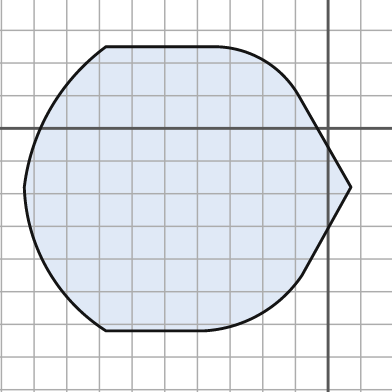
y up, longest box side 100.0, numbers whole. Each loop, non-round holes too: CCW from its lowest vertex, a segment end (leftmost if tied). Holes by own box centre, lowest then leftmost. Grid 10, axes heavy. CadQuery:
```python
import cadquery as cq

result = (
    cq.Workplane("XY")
    .moveTo(-68.0, -62.0)
    .lineTo(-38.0, -62.0)
    .threePointArc((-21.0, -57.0), (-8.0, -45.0))
    .lineTo(7.0, -18.0)
    .lineTo(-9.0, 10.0)
    .threePointArc((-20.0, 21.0), (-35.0, 25.0))
    .lineTo(-68.0, 25.0)
    .threePointArc((-85.0, 6.0), (-93.0, -18.0))
    .threePointArc((-86.0, -43.0), (-68.0, -62.0))
    .close()
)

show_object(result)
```